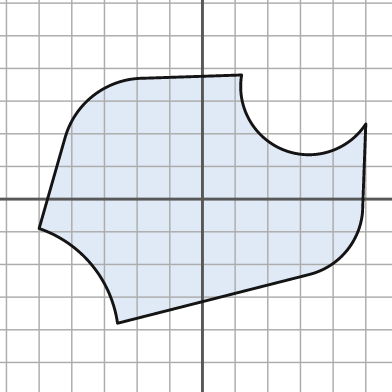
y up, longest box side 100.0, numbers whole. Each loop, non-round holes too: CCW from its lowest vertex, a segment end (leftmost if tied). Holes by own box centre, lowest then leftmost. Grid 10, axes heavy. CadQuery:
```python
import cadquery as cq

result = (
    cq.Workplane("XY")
    .moveTo(-26.0, -38.0)
    .lineTo(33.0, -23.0)
    .threePointArc((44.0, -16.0), (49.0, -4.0))
    .lineTo(50.0, 23.0)
    .threePointArc((25.0, 15.0), (12.0, 38.0))
    .lineTo(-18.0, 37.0)
    .threePointArc((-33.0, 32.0), (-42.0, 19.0))
    .lineTo(-50.0, -9.0)
    .threePointArc((-34.0, -20.0), (-26.0, -38.0))
    .close()
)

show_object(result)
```